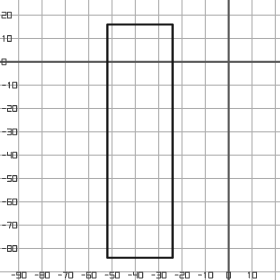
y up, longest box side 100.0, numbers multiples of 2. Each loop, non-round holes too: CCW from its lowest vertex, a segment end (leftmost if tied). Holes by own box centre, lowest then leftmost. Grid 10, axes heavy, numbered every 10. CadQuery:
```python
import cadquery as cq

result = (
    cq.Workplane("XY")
    .moveTo(-52.0, -84.0)
    .lineTo(-24.0, -84.0)
    .lineTo(-24.0, 16.0)
    .lineTo(-52.0, 16.0)
    .close()
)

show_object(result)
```